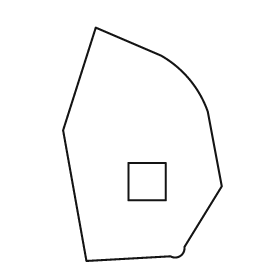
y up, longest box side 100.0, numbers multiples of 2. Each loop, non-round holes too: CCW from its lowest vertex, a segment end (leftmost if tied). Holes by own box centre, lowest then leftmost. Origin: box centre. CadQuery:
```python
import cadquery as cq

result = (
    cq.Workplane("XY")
    .moveTo(-24.0, -50.0)
    .lineTo(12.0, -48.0)
    .threePointArc((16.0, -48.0), (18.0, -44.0))
    .lineTo(34.0, -18.0)
    .lineTo(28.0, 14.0)
    .threePointArc((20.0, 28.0), (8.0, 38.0))
    .lineTo(-20.0, 50.0)
    .lineTo(-34.0, 6.0)
    .close()
    .moveTo(-6.0, -24.0)
    .lineTo(10.0, -24.0)
    .lineTo(10.0, -8.0)
    .lineTo(-6.0, -8.0)
    .close()
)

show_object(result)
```